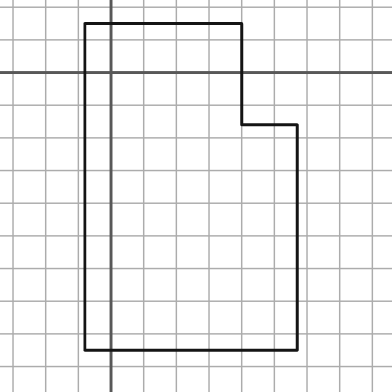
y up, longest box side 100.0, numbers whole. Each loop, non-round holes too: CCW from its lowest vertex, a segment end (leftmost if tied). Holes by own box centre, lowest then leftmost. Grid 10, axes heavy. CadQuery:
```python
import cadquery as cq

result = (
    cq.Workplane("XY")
    .moveTo(-8.0, -85.0)
    .lineTo(57.0, -85.0)
    .lineTo(57.0, -16.0)
    .lineTo(40.0, -16.0)
    .lineTo(40.0, 15.0)
    .lineTo(-8.0, 15.0)
    .close()
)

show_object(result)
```